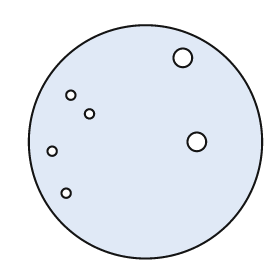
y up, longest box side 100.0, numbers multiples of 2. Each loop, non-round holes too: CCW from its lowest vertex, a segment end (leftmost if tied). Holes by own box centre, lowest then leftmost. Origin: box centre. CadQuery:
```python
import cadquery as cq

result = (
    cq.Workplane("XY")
    .moveTo(0.0, 0.0)
    .circle(50.0)
    .moveTo(-34.0, -22.0)
    .circle(2.0)
    .moveTo(-40.0, -4.0)
    .circle(2.0)
    .moveTo(22.0, 0.0)
    .circle(4.0)
    .moveTo(-24.0, 12.0)
    .circle(2.0)
    .moveTo(-32.0, 20.0)
    .circle(2.0)
    .moveTo(16.0, 36.0)
    .circle(4.0)
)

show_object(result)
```